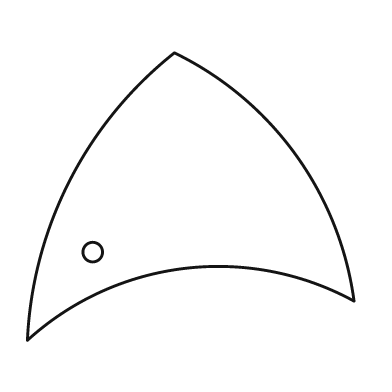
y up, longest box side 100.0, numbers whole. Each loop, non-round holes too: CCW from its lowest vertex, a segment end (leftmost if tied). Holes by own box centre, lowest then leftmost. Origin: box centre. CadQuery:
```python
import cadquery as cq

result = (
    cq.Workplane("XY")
    .moveTo(-50.0, -44.0)
    .threePointArc((-2.0, -22.0), (50.0, -32.0))
    .threePointArc((32.0, 13.0), (-5.0, 44.0))
    .threePointArc((-37.0, 5.0), (-50.0, -44.0))
    .close()
    .moveTo(-30.0, -17.0)
    .circle(3.0)
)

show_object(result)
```